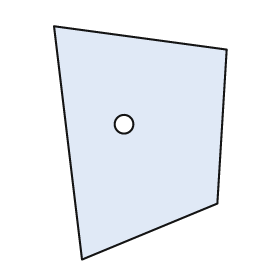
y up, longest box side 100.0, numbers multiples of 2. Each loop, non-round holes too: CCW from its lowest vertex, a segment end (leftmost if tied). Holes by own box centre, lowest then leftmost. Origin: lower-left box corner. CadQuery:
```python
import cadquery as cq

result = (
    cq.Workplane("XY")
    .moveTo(12.0, 0.0)
    .lineTo(70.0, 24.0)
    .lineTo(74.0, 90.0)
    .lineTo(0.0, 100.0)
    .close()
    .moveTo(30.0, 58.0)
    .circle(4.0)
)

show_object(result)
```